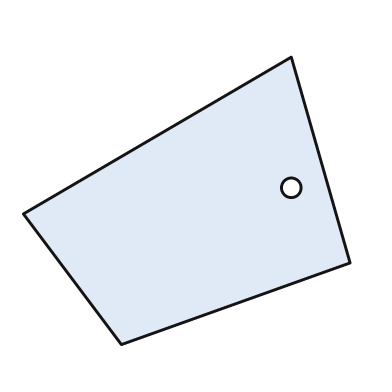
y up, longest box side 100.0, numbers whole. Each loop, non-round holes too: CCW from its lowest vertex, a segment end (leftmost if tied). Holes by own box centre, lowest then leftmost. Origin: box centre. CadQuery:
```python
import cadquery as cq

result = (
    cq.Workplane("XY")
    .moveTo(-20.0, -44.0)
    .lineTo(50.0, -19.0)
    .lineTo(32.0, 44.0)
    .lineTo(-50.0, -4.0)
    .close()
    .moveTo(32.0, 4.0)
    .circle(3.0)
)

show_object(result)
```